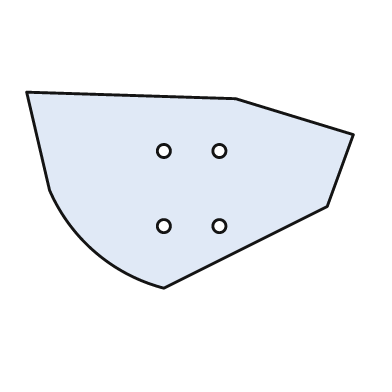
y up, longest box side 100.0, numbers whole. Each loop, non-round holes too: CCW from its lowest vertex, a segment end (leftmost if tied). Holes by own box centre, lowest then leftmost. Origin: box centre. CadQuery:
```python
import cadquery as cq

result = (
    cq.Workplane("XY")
    .moveTo(-8.0, -30.0)
    .lineTo(42.0, -5.0)
    .lineTo(50.0, 17.0)
    .lineTo(14.0, 28.0)
    .lineTo(-50.0, 30.0)
    .lineTo(-43.0, 0.0)
    .threePointArc((-29.0, -19.0), (-8.0, -30.0))
    .close()
    .moveTo(-8.0, -11.0)
    .circle(2.0)
    .moveTo(9.0, -11.0)
    .circle(2.0)
    .moveTo(-8.0, 12.0)
    .circle(2.0)
    .moveTo(9.0, 12.0)
    .circle(2.0)
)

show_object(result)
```